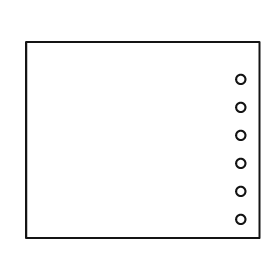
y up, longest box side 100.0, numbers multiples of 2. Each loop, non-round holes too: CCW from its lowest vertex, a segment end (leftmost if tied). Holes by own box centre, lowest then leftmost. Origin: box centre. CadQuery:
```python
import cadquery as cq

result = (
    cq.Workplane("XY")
    .moveTo(-50.0, -42.0)
    .lineTo(50.0, -42.0)
    .lineTo(50.0, 42.0)
    .lineTo(-50.0, 42.0)
    .close()
    .moveTo(42.0, -34.0)
    .circle(2.0)
    .moveTo(42.0, -22.0)
    .circle(2.0)
    .moveTo(42.0, -10.0)
    .circle(2.0)
    .moveTo(42.0, 2.0)
    .circle(2.0)
    .moveTo(42.0, 14.0)
    .circle(2.0)
    .moveTo(42.0, 26.0)
    .circle(2.0)
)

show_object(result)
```